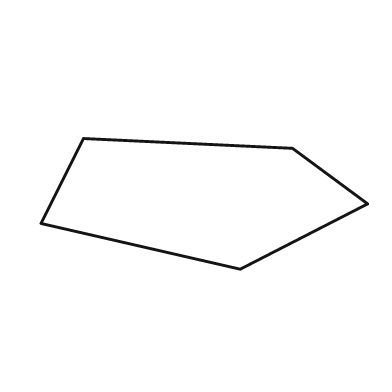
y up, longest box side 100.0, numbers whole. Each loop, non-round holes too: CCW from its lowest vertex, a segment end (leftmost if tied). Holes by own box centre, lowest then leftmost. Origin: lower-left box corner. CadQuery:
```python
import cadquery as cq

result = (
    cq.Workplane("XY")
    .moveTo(61.0, 0.0)
    .lineTo(100.0, 20.0)
    .lineTo(77.0, 37.0)
    .lineTo(13.0, 40.0)
    .lineTo(0.0, 14.0)
    .close()
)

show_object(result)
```